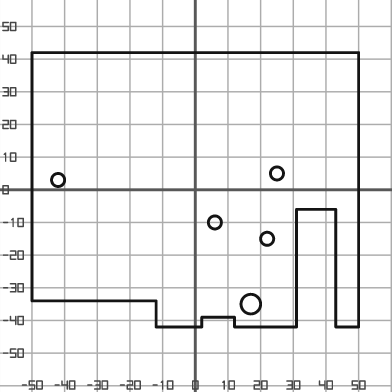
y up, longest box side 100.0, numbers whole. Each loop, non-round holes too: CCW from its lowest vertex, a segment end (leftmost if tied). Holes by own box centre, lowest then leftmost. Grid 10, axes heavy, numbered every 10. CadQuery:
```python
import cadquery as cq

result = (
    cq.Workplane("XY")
    .moveTo(-12.0, -42.0)
    .lineTo(2.0, -42.0)
    .lineTo(2.0, -39.0)
    .lineTo(12.0, -39.0)
    .lineTo(12.0, -42.0)
    .lineTo(31.0, -42.0)
    .lineTo(31.0, -6.0)
    .lineTo(43.0, -6.0)
    .lineTo(43.0, -42.0)
    .lineTo(50.0, -42.0)
    .lineTo(50.0, 42.0)
    .lineTo(-50.0, 42.0)
    .lineTo(-50.0, -34.0)
    .lineTo(-12.0, -34.0)
    .close()
    .moveTo(17.0, -35.0)
    .circle(3.0)
    .moveTo(22.0, -15.0)
    .circle(2.0)
    .moveTo(6.0, -10.0)
    .circle(2.0)
    .moveTo(-42.0, 3.0)
    .circle(2.0)
    .moveTo(25.0, 5.0)
    .circle(2.0)
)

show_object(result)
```